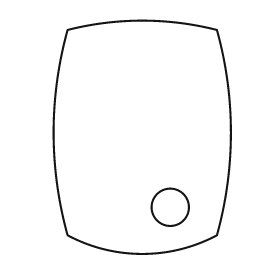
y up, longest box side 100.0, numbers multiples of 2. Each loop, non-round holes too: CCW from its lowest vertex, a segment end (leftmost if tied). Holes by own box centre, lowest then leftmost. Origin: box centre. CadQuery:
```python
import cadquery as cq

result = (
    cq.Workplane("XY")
    .moveTo(-32.0, -42.0)
    .threePointArc((0.0, -50.0), (32.0, -42.0))
    .threePointArc((38.0, 2.0), (32.0, 46.0))
    .threePointArc((0.0, 50.0), (-32.0, 46.0))
    .threePointArc((-38.0, 2.0), (-32.0, -42.0))
    .close()
    .moveTo(12.0, -30.0)
    .circle(8.0)
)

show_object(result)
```